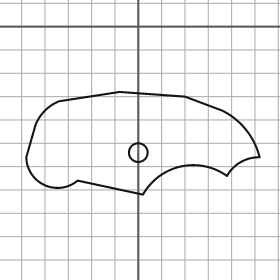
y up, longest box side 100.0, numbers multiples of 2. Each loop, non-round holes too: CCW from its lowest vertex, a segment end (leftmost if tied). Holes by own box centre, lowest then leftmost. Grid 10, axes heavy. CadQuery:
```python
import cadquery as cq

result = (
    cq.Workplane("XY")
    .moveTo(2.0, -72.0)
    .threePointArc((18.0, -60.0), (38.0, -64.0))
    .threePointArc((44.0, -58.0), (52.0, -56.0))
    .threePointArc((46.0, -44.0), (36.0, -36.0))
    .lineTo(20.0, -30.0)
    .lineTo(-8.0, -28.0)
    .lineTo(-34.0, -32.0)
    .threePointArc((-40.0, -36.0), (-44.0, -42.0))
    .lineTo(-48.0, -56.0)
    .threePointArc((-40.0, -68.0), (-26.0, -66.0))
    .close()
    .moveTo(0.0, -54.0)
    .circle(4.0)
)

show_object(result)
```